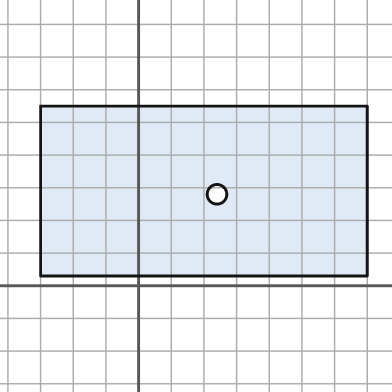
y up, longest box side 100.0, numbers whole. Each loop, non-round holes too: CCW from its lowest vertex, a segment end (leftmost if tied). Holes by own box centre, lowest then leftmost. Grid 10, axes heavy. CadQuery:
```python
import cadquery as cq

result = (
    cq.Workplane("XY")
    .moveTo(-30.0, 3.0)
    .lineTo(70.0, 3.0)
    .lineTo(70.0, 55.0)
    .lineTo(-30.0, 55.0)
    .close()
    .moveTo(24.0, 28.0)
    .circle(3.0)
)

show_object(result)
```